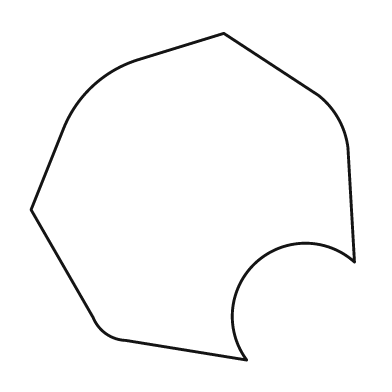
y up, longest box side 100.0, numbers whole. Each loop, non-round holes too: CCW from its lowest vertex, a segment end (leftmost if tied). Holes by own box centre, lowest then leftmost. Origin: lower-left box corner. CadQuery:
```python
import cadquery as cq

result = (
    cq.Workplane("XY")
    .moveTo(66.0, 0.0)
    .threePointArc((69.0, 30.0), (99.0, 30.0))
    .lineTo(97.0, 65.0)
    .threePointArc((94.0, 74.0), (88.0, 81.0))
    .lineTo(59.0, 100.0)
    .lineTo(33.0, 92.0)
    .threePointArc((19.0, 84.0), (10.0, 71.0))
    .lineTo(0.0, 46.0)
    .lineTo(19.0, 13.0)
    .threePointArc((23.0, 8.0), (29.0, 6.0))
    .close()
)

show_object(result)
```